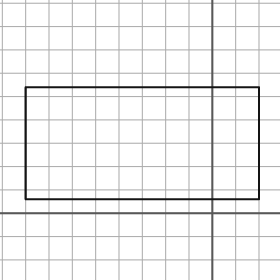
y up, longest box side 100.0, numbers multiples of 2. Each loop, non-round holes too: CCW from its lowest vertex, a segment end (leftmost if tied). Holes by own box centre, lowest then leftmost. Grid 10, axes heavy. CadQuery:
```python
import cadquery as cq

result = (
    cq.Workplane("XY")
    .moveTo(-80.0, 6.0)
    .lineTo(20.0, 6.0)
    .lineTo(20.0, 54.0)
    .lineTo(-80.0, 54.0)
    .close()
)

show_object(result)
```